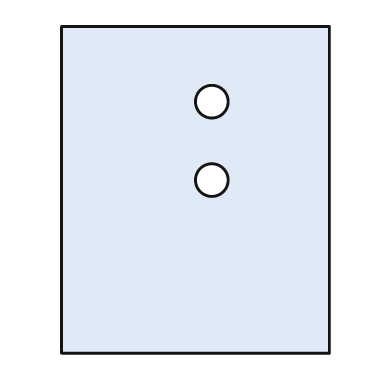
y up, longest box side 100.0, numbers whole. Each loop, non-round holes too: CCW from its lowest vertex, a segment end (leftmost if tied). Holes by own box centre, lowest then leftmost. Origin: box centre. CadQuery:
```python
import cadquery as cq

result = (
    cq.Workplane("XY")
    .moveTo(-41.0, -50.0)
    .lineTo(41.0, -50.0)
    .lineTo(41.0, 50.0)
    .lineTo(-41.0, 50.0)
    .close()
    .moveTo(5.0, 3.0)
    .circle(5.0)
    .moveTo(5.0, 27.0)
    .circle(5.0)
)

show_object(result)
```